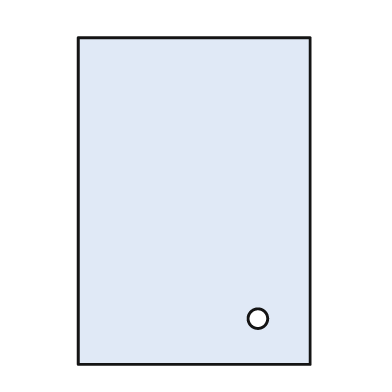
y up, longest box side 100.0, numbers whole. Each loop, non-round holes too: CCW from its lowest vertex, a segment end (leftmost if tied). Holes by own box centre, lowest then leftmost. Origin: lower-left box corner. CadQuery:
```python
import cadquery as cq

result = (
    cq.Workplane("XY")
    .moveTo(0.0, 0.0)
    .lineTo(71.0, 0.0)
    .lineTo(71.0, 100.0)
    .lineTo(0.0, 100.0)
    .close()
    .moveTo(55.0, 14.0)
    .circle(3.0)
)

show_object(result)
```